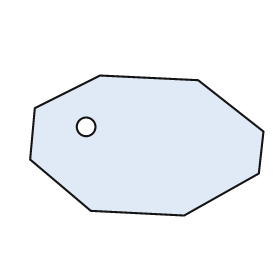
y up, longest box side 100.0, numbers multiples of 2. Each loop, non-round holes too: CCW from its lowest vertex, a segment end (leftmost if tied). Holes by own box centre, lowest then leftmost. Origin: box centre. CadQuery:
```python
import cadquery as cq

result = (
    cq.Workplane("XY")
    .moveTo(16.0, -30.0)
    .lineTo(48.0, -12.0)
    .lineTo(50.0, 6.0)
    .lineTo(22.0, 28.0)
    .lineTo(-20.0, 30.0)
    .lineTo(-48.0, 16.0)
    .lineTo(-50.0, -6.0)
    .lineTo(-24.0, -28.0)
    .close()
    .moveTo(-26.0, 8.0)
    .circle(4.0)
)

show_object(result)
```